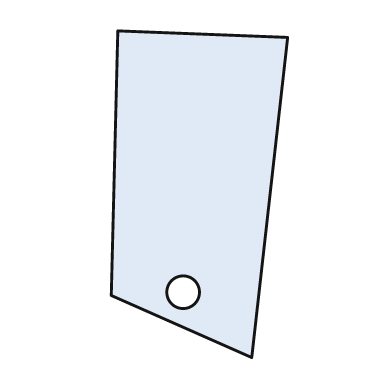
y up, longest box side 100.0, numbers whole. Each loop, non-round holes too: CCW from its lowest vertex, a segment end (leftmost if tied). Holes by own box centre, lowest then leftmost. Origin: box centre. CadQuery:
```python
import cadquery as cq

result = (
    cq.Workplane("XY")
    .moveTo(16.0, -50.0)
    .lineTo(27.0, 48.0)
    .lineTo(-25.0, 50.0)
    .lineTo(-27.0, -31.0)
    .close()
    .moveTo(-5.0, -30.0)
    .circle(5.0)
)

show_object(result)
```